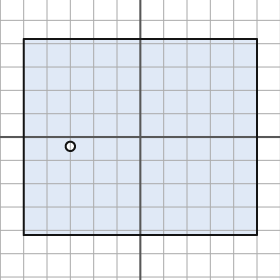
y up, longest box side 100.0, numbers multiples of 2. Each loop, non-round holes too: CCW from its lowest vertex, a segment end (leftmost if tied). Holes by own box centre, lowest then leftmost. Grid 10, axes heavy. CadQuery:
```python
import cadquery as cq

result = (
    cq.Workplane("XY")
    .moveTo(-50.0, -42.0)
    .lineTo(50.0, -42.0)
    .lineTo(50.0, 42.0)
    .lineTo(-50.0, 42.0)
    .close()
    .moveTo(-30.0, -4.0)
    .circle(2.0)
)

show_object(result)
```